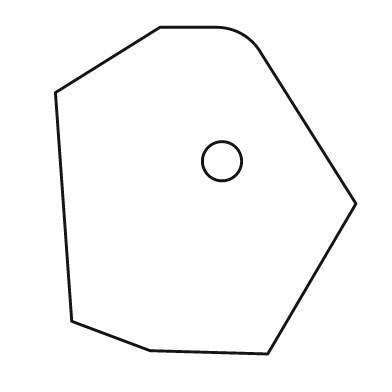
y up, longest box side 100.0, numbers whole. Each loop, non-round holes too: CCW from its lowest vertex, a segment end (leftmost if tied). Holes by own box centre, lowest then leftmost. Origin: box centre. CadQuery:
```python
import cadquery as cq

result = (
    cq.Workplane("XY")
    .moveTo(19.0, -50.0)
    .lineTo(46.0, -4.0)
    .lineTo(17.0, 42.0)
    .threePointArc((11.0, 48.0), (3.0, 50.0))
    .lineTo(-14.0, 50.0)
    .lineTo(-46.0, 30.0)
    .lineTo(-41.0, -40.0)
    .lineTo(-17.0, -49.0)
    .close()
    .moveTo(5.0, 9.0)
    .circle(6.0)
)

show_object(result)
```